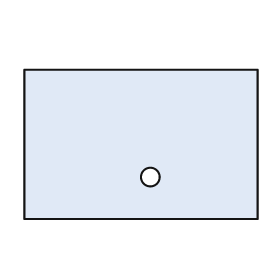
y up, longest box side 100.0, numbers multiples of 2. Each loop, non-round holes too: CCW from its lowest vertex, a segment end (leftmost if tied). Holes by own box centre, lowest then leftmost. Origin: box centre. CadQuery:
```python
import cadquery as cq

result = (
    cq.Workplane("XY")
    .moveTo(-50.0, -32.0)
    .lineTo(50.0, -32.0)
    .lineTo(50.0, 32.0)
    .lineTo(-50.0, 32.0)
    .close()
    .moveTo(4.0, -14.0)
    .circle(4.0)
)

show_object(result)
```